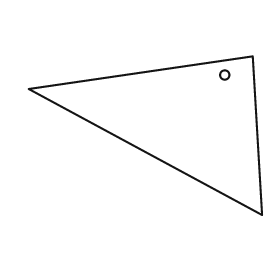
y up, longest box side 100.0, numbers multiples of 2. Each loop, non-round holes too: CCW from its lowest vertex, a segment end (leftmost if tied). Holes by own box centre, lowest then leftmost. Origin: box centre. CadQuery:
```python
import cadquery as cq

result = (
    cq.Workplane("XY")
    .moveTo(50.0, -34.0)
    .lineTo(46.0, 34.0)
    .lineTo(-50.0, 20.0)
    .close()
    .moveTo(34.0, 26.0)
    .circle(2.0)
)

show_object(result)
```